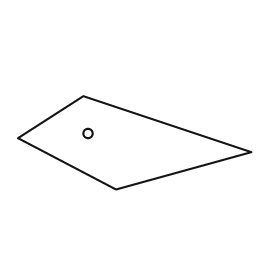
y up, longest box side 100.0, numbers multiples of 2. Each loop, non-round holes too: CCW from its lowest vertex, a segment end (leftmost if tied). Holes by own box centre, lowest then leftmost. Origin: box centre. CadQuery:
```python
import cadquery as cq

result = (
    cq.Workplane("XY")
    .moveTo(-8.0, -20.0)
    .lineTo(50.0, -4.0)
    .lineTo(-22.0, 20.0)
    .lineTo(-50.0, 2.0)
    .close()
    .moveTo(-20.0, 4.0)
    .circle(2.0)
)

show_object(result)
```